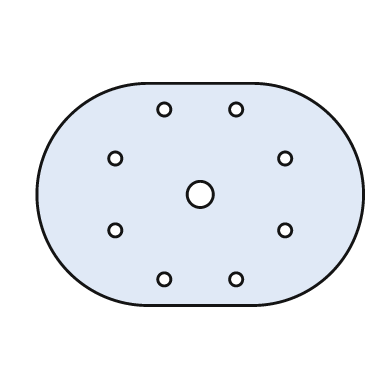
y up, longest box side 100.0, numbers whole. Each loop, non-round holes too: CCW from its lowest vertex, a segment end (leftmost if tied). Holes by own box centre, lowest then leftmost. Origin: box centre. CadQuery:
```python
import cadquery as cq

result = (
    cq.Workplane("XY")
    .moveTo(-16.0, -34.0)
    .lineTo(16.0, -34.0)
    .threePointArc((50.0, 0.0), (16.0, 34.0))
    .lineTo(-16.0, 34.0)
    .threePointArc((-50.0, 0.0), (-16.0, -34.0))
    .close()
    .moveTo(-11.0, -26.0)
    .circle(2.0)
    .moveTo(11.0, -26.0)
    .circle(2.0)
    .moveTo(-26.0, -11.0)
    .circle(2.0)
    .moveTo(26.0, -11.0)
    .circle(2.0)
    .moveTo(0.0, 0.0)
    .circle(4.0)
    .moveTo(-26.0, 11.0)
    .circle(2.0)
    .moveTo(26.0, 11.0)
    .circle(2.0)
    .moveTo(-11.0, 26.0)
    .circle(2.0)
    .moveTo(11.0, 26.0)
    .circle(2.0)
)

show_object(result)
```